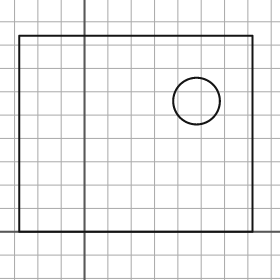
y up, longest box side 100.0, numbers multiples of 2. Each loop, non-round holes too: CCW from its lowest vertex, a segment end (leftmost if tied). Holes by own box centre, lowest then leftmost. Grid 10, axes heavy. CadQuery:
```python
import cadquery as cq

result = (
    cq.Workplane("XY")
    .moveTo(-28.0, 0.0)
    .lineTo(72.0, 0.0)
    .lineTo(72.0, 84.0)
    .lineTo(-28.0, 84.0)
    .close()
    .moveTo(48.0, 56.0)
    .circle(10.0)
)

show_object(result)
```